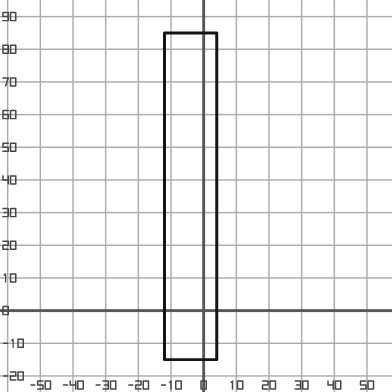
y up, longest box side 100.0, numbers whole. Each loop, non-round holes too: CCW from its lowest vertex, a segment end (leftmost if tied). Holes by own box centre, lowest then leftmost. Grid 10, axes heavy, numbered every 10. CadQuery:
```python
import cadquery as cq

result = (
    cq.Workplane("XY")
    .moveTo(-12.0, -15.0)
    .lineTo(4.0, -15.0)
    .lineTo(4.0, 85.0)
    .lineTo(-12.0, 85.0)
    .close()
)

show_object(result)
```